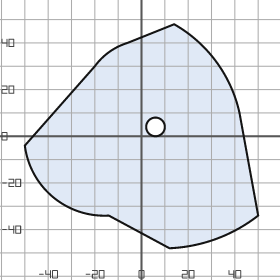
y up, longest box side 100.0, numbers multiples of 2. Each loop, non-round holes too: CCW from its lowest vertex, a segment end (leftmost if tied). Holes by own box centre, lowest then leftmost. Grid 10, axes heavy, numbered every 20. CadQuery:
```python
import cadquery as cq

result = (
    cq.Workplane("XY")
    .moveTo(12.0, -48.0)
    .threePointArc((32.0, -44.0), (50.0, -34.0))
    .lineTo(42.0, 10.0)
    .threePointArc((32.0, 32.0), (14.0, 48.0))
    .lineTo(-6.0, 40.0)
    .threePointArc((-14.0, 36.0), (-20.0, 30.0))
    .lineTo(-50.0, -4.0)
    .threePointArc((-38.0, -26.0), (-14.0, -34.0))
    .close()
    .moveTo(6.0, 4.0)
    .circle(4.0)
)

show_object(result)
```